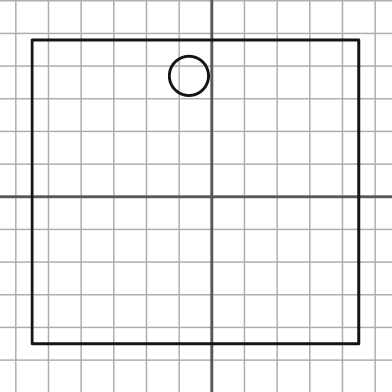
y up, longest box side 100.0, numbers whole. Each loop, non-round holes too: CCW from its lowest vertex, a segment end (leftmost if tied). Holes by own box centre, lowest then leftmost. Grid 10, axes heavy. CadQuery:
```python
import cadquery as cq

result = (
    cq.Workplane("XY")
    .moveTo(-55.0, -45.0)
    .lineTo(45.0, -45.0)
    .lineTo(45.0, 48.0)
    .lineTo(-55.0, 48.0)
    .close()
    .moveTo(-7.0, 37.0)
    .circle(6.0)
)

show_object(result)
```